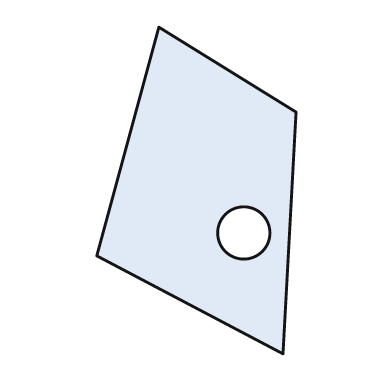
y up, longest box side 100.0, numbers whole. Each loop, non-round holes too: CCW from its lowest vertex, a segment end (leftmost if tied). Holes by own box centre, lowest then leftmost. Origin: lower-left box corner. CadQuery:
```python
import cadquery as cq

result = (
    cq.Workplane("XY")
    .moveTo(57.0, 0.0)
    .lineTo(61.0, 74.0)
    .lineTo(19.0, 100.0)
    .lineTo(0.0, 30.0)
    .close()
    .moveTo(45.0, 37.0)
    .circle(8.0)
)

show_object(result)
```